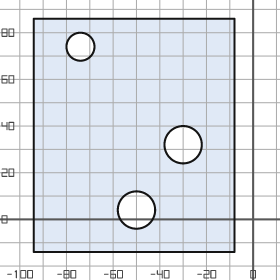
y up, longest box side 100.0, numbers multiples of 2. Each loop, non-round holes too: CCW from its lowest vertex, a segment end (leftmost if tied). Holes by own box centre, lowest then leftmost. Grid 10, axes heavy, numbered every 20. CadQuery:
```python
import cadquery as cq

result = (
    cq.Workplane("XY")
    .moveTo(-94.0, -14.0)
    .lineTo(-8.0, -14.0)
    .lineTo(-8.0, 86.0)
    .lineTo(-94.0, 86.0)
    .close()
    .moveTo(-50.0, 4.0)
    .circle(8.0)
    .moveTo(-30.0, 32.0)
    .circle(8.0)
    .moveTo(-74.0, 74.0)
    .circle(6.0)
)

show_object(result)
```